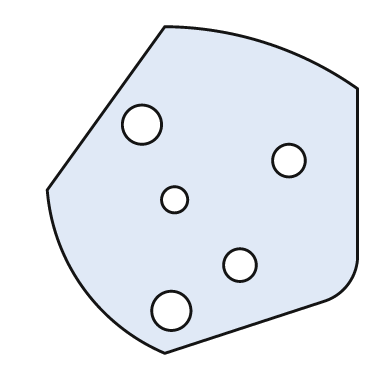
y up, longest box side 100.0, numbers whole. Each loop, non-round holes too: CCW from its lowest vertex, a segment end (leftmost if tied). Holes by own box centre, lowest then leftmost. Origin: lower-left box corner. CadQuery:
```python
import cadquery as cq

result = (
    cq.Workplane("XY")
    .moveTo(36.0, 0.0)
    .lineTo(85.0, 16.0)
    .threePointArc((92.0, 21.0), (95.0, 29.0))
    .lineTo(95.0, 81.0)
    .threePointArc((67.0, 95.0), (36.0, 100.0))
    .lineTo(0.0, 50.0)
    .threePointArc((11.0, 20.0), (36.0, 0.0))
    .close()
    .moveTo(38.0, 13.0)
    .circle(6.0)
    .moveTo(59.0, 27.0)
    .circle(5.0)
    .moveTo(39.0, 47.0)
    .circle(4.0)
    .moveTo(74.0, 59.0)
    .circle(5.0)
    .moveTo(29.0, 70.0)
    .circle(6.0)
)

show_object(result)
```